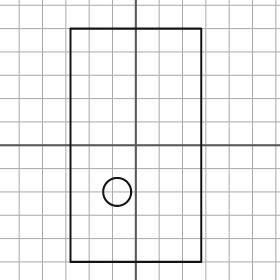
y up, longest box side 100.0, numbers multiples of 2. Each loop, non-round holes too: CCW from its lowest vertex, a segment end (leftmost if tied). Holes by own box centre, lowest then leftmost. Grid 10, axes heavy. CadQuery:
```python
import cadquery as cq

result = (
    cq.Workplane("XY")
    .moveTo(-28.0, -50.0)
    .lineTo(28.0, -50.0)
    .lineTo(28.0, 50.0)
    .lineTo(-28.0, 50.0)
    .close()
    .moveTo(-8.0, -20.0)
    .circle(6.0)
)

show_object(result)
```